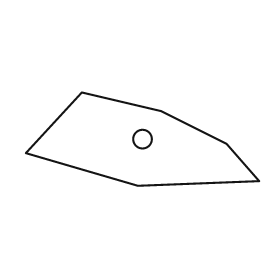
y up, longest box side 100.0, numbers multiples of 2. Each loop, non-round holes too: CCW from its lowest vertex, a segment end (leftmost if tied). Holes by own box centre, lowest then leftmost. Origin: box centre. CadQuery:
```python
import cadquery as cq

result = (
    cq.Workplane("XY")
    .moveTo(-2.0, -20.0)
    .lineTo(50.0, -18.0)
    .lineTo(36.0, -2.0)
    .lineTo(8.0, 12.0)
    .lineTo(-26.0, 20.0)
    .lineTo(-50.0, -6.0)
    .close()
    .moveTo(0.0, 0.0)
    .circle(4.0)
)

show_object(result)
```